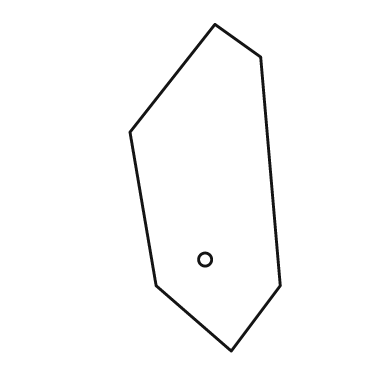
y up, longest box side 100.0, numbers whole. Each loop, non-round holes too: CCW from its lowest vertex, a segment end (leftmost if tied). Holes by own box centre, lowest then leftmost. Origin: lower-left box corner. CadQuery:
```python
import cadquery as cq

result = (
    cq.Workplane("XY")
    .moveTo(31.0, 0.0)
    .lineTo(46.0, 20.0)
    .lineTo(40.0, 90.0)
    .lineTo(26.0, 100.0)
    .lineTo(0.0, 67.0)
    .lineTo(8.0, 20.0)
    .close()
    .moveTo(23.0, 28.0)
    .circle(2.0)
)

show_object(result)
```